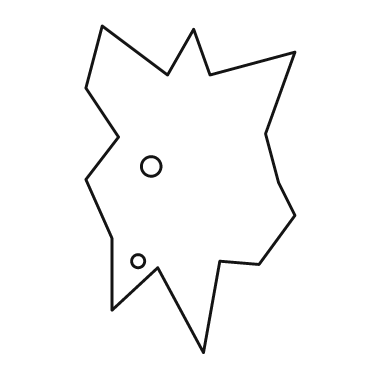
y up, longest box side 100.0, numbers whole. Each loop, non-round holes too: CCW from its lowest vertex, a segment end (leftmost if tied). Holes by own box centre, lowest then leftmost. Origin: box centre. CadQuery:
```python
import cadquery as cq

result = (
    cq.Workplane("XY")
    .moveTo(4.0, -50.0)
    .lineTo(9.0, -22.0)
    .lineTo(21.0, -23.0)
    .lineTo(32.0, -8.0)
    .lineTo(27.0, 2.0)
    .lineTo(23.0, 17.0)
    .lineTo(32.0, 42.0)
    .lineTo(6.0, 35.0)
    .lineTo(1.0, 49.0)
    .lineTo(-7.0, 35.0)
    .lineTo(-27.0, 50.0)
    .lineTo(-32.0, 31.0)
    .lineTo(-22.0, 16.0)
    .lineTo(-32.0, 3.0)
    .lineTo(-24.0, -15.0)
    .lineTo(-24.0, -37.0)
    .lineTo(-10.0, -24.0)
    .close()
    .moveTo(-16.0, -22.0)
    .circle(2.0)
    .moveTo(-12.0, 7.0)
    .circle(3.0)
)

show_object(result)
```